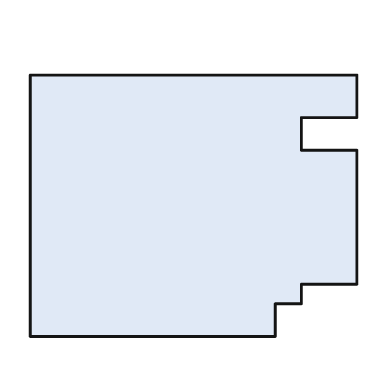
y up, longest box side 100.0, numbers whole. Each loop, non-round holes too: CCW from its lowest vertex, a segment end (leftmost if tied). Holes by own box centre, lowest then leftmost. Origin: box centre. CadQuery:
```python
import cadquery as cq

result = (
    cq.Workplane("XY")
    .moveTo(-50.0, -40.0)
    .lineTo(25.0, -40.0)
    .lineTo(25.0, -30.0)
    .lineTo(33.0, -30.0)
    .lineTo(33.0, -24.0)
    .lineTo(50.0, -24.0)
    .lineTo(50.0, 17.0)
    .lineTo(33.0, 17.0)
    .lineTo(33.0, 27.0)
    .lineTo(50.0, 27.0)
    .lineTo(50.0, 40.0)
    .lineTo(-50.0, 40.0)
    .close()
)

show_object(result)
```